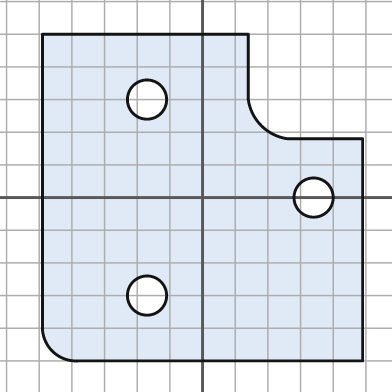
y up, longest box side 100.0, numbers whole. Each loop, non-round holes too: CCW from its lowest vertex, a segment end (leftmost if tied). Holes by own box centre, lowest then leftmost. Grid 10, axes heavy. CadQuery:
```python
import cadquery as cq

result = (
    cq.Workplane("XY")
    .moveTo(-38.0, -50.0)
    .lineTo(49.0, -50.0)
    .lineTo(49.0, 18.0)
    .lineTo(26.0, 18.0)
    .threePointArc((18.0, 22.0), (14.0, 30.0))
    .lineTo(14.0, 50.0)
    .lineTo(-49.0, 50.0)
    .lineTo(-49.0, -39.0)
    .threePointArc((-46.0, -47.0), (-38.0, -50.0))
    .close()
    .moveTo(-17.0, -30.0)
    .circle(6.0)
    .moveTo(34.0, 0.0)
    .circle(6.0)
    .moveTo(-17.0, 30.0)
    .circle(6.0)
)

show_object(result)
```